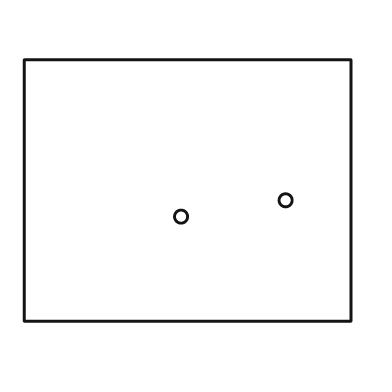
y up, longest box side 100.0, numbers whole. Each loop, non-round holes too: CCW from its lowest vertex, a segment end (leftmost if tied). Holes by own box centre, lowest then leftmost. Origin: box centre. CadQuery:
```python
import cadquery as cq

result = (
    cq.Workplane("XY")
    .moveTo(-50.0, -40.0)
    .lineTo(50.0, -40.0)
    .lineTo(50.0, 40.0)
    .lineTo(-50.0, 40.0)
    .close()
    .moveTo(-2.0, -8.0)
    .circle(2.0)
    .moveTo(30.0, -3.0)
    .circle(2.0)
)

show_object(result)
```